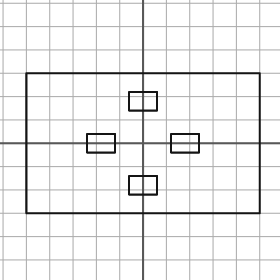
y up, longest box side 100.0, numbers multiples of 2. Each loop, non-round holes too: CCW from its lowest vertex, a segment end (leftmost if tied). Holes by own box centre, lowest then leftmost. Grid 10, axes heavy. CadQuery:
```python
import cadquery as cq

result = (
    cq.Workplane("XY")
    .moveTo(-50.0, -30.0)
    .lineTo(50.0, -30.0)
    .lineTo(50.0, 30.0)
    .lineTo(-50.0, 30.0)
    .close()
    .moveTo(-6.0, -22.0)
    .lineTo(6.0, -22.0)
    .lineTo(6.0, -14.0)
    .lineTo(-6.0, -14.0)
    .close()
    .moveTo(-24.0, -4.0)
    .lineTo(-12.0, -4.0)
    .lineTo(-12.0, 4.0)
    .lineTo(-24.0, 4.0)
    .close()
    .moveTo(12.0, -4.0)
    .lineTo(24.0, -4.0)
    .lineTo(24.0, 4.0)
    .lineTo(12.0, 4.0)
    .close()
    .moveTo(-6.0, 14.0)
    .lineTo(6.0, 14.0)
    .lineTo(6.0, 22.0)
    .lineTo(-6.0, 22.0)
    .close()
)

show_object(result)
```